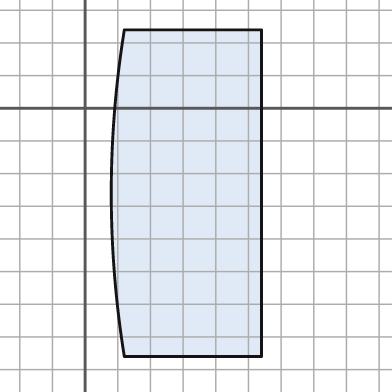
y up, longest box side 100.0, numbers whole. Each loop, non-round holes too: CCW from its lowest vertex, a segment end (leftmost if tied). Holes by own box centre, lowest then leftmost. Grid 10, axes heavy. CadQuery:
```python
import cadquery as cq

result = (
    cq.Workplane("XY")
    .moveTo(12.0, -76.0)
    .lineTo(54.0, -76.0)
    .lineTo(54.0, 24.0)
    .lineTo(12.0, 24.0)
    .threePointArc((8.0, -26.0), (12.0, -76.0))
    .close()
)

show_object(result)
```